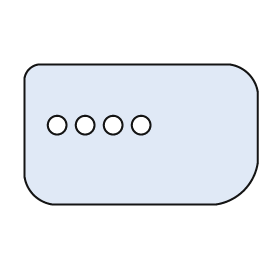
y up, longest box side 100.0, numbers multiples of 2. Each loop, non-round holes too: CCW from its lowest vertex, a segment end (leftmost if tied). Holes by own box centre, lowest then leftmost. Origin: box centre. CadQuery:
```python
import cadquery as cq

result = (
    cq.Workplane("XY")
    .moveTo(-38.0, -30.0)
    .lineTo(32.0, -30.0)
    .threePointArc((44.0, -24.0), (50.0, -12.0))
    .lineTo(50.0, 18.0)
    .threePointArc((46.0, 26.0), (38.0, 30.0))
    .lineTo(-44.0, 30.0)
    .threePointArc((-48.0, 28.0), (-50.0, 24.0))
    .lineTo(-50.0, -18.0)
    .threePointArc((-46.0, -26.0), (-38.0, -30.0))
    .close()
    .moveTo(-36.0, 4.0)
    .circle(4.0)
    .moveTo(-24.0, 4.0)
    .circle(4.0)
    .moveTo(-12.0, 4.0)
    .circle(4.0)
    .moveTo(0.0, 4.0)
    .circle(4.0)
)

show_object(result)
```